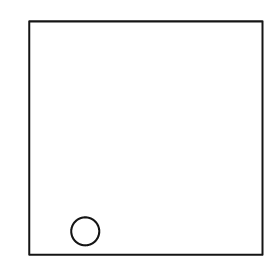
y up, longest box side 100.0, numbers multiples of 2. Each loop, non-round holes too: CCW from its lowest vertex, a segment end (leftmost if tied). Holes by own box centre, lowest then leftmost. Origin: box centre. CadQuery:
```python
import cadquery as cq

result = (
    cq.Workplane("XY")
    .moveTo(-50.0, -50.0)
    .lineTo(50.0, -50.0)
    .lineTo(50.0, 50.0)
    .lineTo(-50.0, 50.0)
    .close()
    .moveTo(-26.0, -40.0)
    .circle(6.0)
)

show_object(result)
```